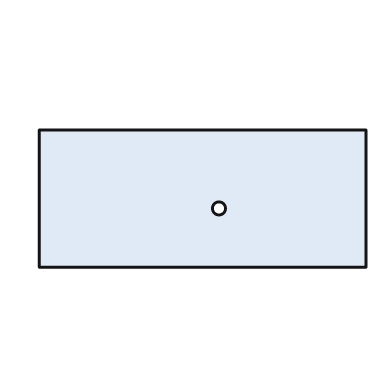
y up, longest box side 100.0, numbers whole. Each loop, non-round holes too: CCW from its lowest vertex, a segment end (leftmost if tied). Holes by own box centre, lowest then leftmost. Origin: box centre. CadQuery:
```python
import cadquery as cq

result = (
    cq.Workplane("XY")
    .moveTo(-50.0, -21.0)
    .lineTo(50.0, -21.0)
    .lineTo(50.0, 21.0)
    .lineTo(-50.0, 21.0)
    .close()
    .moveTo(5.0, -3.0)
    .circle(2.0)
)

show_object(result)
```